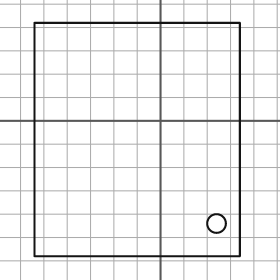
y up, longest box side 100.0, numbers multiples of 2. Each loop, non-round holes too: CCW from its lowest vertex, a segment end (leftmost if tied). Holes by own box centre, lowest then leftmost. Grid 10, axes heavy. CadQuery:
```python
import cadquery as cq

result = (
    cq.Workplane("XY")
    .moveTo(-54.0, -58.0)
    .lineTo(34.0, -58.0)
    .lineTo(34.0, 42.0)
    .lineTo(-54.0, 42.0)
    .close()
    .moveTo(24.0, -44.0)
    .circle(4.0)
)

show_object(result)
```